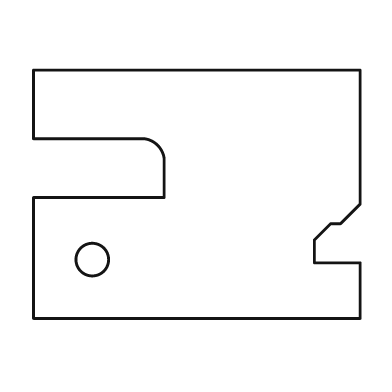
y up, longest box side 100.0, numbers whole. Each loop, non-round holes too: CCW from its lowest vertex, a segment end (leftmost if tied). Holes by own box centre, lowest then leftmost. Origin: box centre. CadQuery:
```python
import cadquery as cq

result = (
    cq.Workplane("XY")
    .moveTo(-50.0, -38.0)
    .lineTo(50.0, -38.0)
    .lineTo(50.0, -21.0)
    .lineTo(36.0, -21.0)
    .lineTo(36.0, -14.0)
    .lineTo(41.0, -9.0)
    .lineTo(44.0, -9.0)
    .lineTo(50.0, -3.0)
    .lineTo(50.0, 38.0)
    .lineTo(-50.0, 38.0)
    .lineTo(-50.0, 17.0)
    .lineTo(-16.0, 17.0)
    .threePointArc((-12.0, 15.0), (-10.0, 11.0))
    .lineTo(-10.0, -1.0)
    .lineTo(-50.0, -1.0)
    .close()
    .moveTo(-32.0, -20.0)
    .circle(5.0)
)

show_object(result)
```